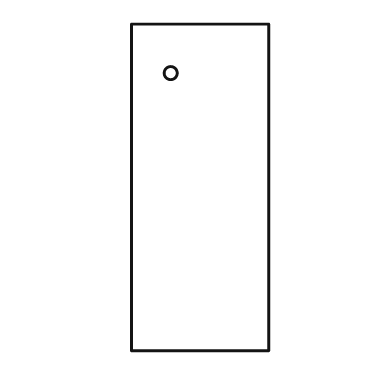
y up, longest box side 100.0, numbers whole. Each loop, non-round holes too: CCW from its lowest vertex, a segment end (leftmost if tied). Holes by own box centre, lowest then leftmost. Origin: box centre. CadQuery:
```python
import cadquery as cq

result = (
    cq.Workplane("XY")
    .moveTo(-21.0, -50.0)
    .lineTo(21.0, -50.0)
    .lineTo(21.0, 50.0)
    .lineTo(-21.0, 50.0)
    .close()
    .moveTo(-9.0, 35.0)
    .circle(2.0)
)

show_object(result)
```